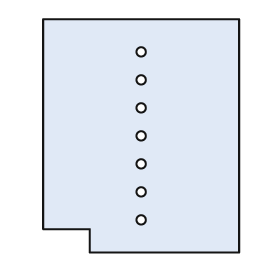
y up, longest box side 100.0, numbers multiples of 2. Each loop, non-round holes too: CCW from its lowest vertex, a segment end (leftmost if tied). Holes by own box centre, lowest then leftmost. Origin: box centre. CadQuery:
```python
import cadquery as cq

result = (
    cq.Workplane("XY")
    .moveTo(-22.0, -50.0)
    .lineTo(42.0, -50.0)
    .lineTo(42.0, 50.0)
    .lineTo(-42.0, 50.0)
    .lineTo(-42.0, -40.0)
    .lineTo(-22.0, -40.0)
    .close()
    .moveTo(0.0, -36.0)
    .circle(2.0)
    .moveTo(0.0, -24.0)
    .circle(2.0)
    .moveTo(0.0, -12.0)
    .circle(2.0)
    .moveTo(0.0, 0.0)
    .circle(2.0)
    .moveTo(0.0, 12.0)
    .circle(2.0)
    .moveTo(0.0, 24.0)
    .circle(2.0)
    .moveTo(0.0, 36.0)
    .circle(2.0)
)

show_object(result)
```